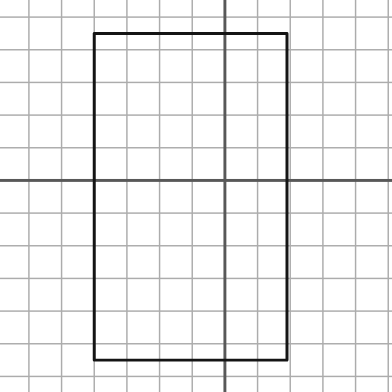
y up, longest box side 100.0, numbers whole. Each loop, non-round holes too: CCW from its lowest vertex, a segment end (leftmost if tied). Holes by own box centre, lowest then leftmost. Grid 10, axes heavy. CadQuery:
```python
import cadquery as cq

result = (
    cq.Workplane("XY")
    .moveTo(-40.0, -55.0)
    .lineTo(19.0, -55.0)
    .lineTo(19.0, 45.0)
    .lineTo(-40.0, 45.0)
    .close()
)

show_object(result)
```